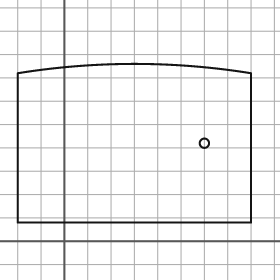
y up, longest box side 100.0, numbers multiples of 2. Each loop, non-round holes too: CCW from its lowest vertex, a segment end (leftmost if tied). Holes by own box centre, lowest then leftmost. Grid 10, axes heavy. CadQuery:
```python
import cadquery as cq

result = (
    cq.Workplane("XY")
    .moveTo(-20.0, 8.0)
    .lineTo(80.0, 8.0)
    .lineTo(80.0, 72.0)
    .threePointArc((30.0, 76.0), (-20.0, 72.0))
    .close()
    .moveTo(60.0, 42.0)
    .circle(2.0)
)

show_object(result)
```